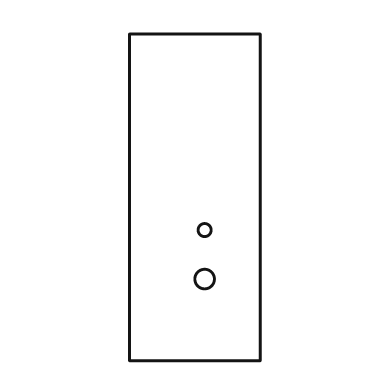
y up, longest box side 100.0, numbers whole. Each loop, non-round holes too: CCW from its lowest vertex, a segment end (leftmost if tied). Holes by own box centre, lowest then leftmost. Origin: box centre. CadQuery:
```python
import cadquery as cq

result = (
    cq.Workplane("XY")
    .moveTo(-20.0, -50.0)
    .lineTo(20.0, -50.0)
    .lineTo(20.0, 50.0)
    .lineTo(-20.0, 50.0)
    .close()
    .moveTo(3.0, -25.0)
    .circle(3.0)
    .moveTo(3.0, -10.0)
    .circle(2.0)
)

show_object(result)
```